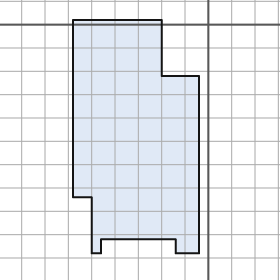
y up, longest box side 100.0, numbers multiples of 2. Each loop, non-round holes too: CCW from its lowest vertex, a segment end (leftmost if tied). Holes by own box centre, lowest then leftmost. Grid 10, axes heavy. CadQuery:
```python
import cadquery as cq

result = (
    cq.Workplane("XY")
    .moveTo(-50.0, -98.0)
    .lineTo(-46.0, -98.0)
    .lineTo(-46.0, -92.0)
    .lineTo(-14.0, -92.0)
    .lineTo(-14.0, -98.0)
    .lineTo(-4.0, -98.0)
    .lineTo(-4.0, -22.0)
    .lineTo(-20.0, -22.0)
    .lineTo(-20.0, 2.0)
    .lineTo(-58.0, 2.0)
    .lineTo(-58.0, -74.0)
    .lineTo(-50.0, -74.0)
    .close()
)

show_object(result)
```